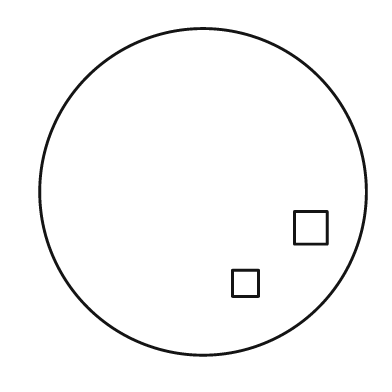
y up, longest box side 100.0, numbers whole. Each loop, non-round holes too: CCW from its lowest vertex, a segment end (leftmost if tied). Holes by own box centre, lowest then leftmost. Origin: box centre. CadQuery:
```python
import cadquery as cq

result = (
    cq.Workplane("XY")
    .moveTo(0.0, 0.0)
    .circle(50.0)
    .moveTo(9.0, -32.0)
    .lineTo(17.0, -32.0)
    .lineTo(17.0, -24.0)
    .lineTo(9.0, -24.0)
    .close()
    .moveTo(28.0, -16.0)
    .lineTo(38.0, -16.0)
    .lineTo(38.0, -6.0)
    .lineTo(28.0, -6.0)
    .close()
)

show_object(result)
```